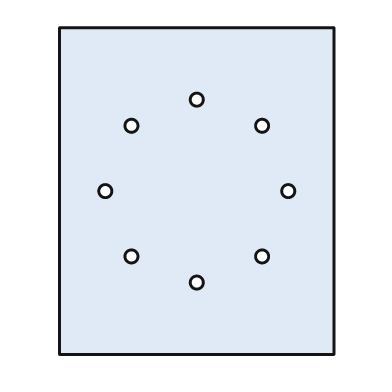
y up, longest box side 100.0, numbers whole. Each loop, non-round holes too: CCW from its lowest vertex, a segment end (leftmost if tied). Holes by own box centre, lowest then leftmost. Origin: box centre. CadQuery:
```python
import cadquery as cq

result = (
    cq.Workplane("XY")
    .moveTo(-42.0, -50.0)
    .lineTo(42.0, -50.0)
    .lineTo(42.0, 50.0)
    .lineTo(-42.0, 50.0)
    .close()
    .moveTo(0.0, -28.0)
    .circle(2.0)
    .moveTo(-20.0, -20.0)
    .circle(2.0)
    .moveTo(20.0, -20.0)
    .circle(2.0)
    .moveTo(-28.0, 0.0)
    .circle(2.0)
    .moveTo(28.0, 0.0)
    .circle(2.0)
    .moveTo(-20.0, 20.0)
    .circle(2.0)
    .moveTo(20.0, 20.0)
    .circle(2.0)
    .moveTo(0.0, 28.0)
    .circle(2.0)
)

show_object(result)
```